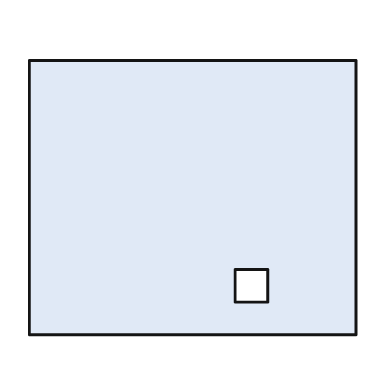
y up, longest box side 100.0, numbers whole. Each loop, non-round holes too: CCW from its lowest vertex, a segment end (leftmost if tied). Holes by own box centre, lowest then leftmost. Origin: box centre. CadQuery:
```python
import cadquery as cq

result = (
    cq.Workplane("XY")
    .moveTo(-50.0, -42.0)
    .lineTo(50.0, -42.0)
    .lineTo(50.0, 42.0)
    .lineTo(-50.0, 42.0)
    .close()
    .moveTo(13.0, -32.0)
    .lineTo(23.0, -32.0)
    .lineTo(23.0, -22.0)
    .lineTo(13.0, -22.0)
    .close()
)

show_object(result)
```